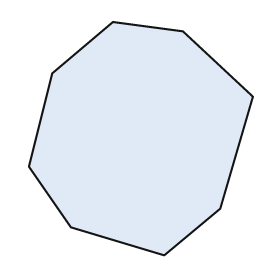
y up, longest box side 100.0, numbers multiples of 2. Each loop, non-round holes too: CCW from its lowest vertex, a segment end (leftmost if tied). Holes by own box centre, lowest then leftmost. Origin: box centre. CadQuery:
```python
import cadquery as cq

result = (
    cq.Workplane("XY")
    .moveTo(10.0, -50.0)
    .lineTo(34.0, -30.0)
    .lineTo(48.0, 18.0)
    .lineTo(18.0, 46.0)
    .lineTo(-12.0, 50.0)
    .lineTo(-38.0, 28.0)
    .lineTo(-48.0, -12.0)
    .lineTo(-30.0, -38.0)
    .close()
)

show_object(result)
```